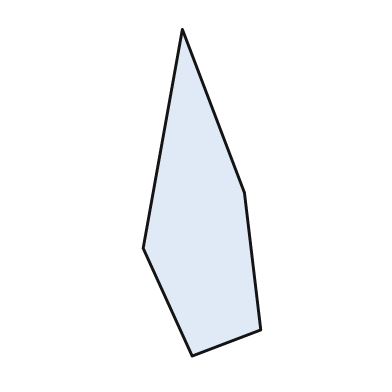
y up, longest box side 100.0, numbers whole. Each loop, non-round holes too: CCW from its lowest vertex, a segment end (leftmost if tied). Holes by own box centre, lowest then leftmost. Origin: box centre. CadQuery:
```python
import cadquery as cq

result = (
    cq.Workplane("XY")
    .moveTo(-3.0, -50.0)
    .lineTo(18.0, -42.0)
    .lineTo(13.0, 0.0)
    .lineTo(-6.0, 50.0)
    .lineTo(-18.0, -17.0)
    .close()
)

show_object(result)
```